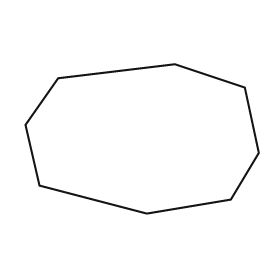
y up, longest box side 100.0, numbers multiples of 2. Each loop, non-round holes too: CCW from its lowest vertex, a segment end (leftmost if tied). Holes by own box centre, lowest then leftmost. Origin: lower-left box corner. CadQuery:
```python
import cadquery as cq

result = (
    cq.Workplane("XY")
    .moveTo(52.0, 0.0)
    .lineTo(88.0, 6.0)
    .lineTo(100.0, 26.0)
    .lineTo(94.0, 54.0)
    .lineTo(64.0, 64.0)
    .lineTo(14.0, 58.0)
    .lineTo(0.0, 38.0)
    .lineTo(6.0, 12.0)
    .close()
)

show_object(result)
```